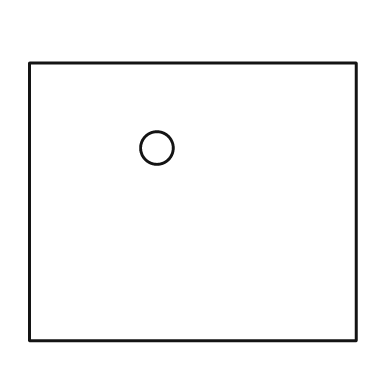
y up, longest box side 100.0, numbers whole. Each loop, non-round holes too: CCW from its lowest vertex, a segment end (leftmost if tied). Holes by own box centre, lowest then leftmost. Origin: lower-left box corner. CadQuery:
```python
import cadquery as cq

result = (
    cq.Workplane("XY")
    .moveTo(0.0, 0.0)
    .lineTo(100.0, 0.0)
    .lineTo(100.0, 85.0)
    .lineTo(0.0, 85.0)
    .close()
    .moveTo(39.0, 59.0)
    .circle(5.0)
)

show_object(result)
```